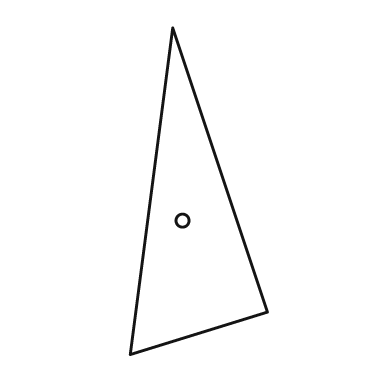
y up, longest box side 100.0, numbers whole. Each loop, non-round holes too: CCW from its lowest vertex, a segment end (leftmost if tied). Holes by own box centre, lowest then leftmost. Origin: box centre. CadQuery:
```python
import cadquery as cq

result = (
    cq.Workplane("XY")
    .moveTo(-21.0, -50.0)
    .lineTo(21.0, -37.0)
    .lineTo(-8.0, 50.0)
    .close()
    .moveTo(-5.0, -9.0)
    .circle(2.0)
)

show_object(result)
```